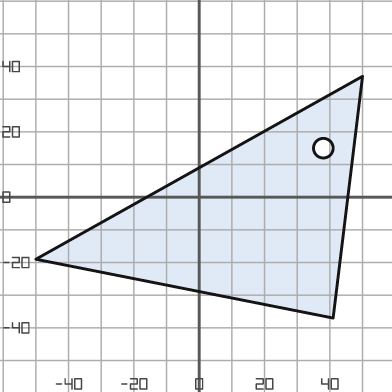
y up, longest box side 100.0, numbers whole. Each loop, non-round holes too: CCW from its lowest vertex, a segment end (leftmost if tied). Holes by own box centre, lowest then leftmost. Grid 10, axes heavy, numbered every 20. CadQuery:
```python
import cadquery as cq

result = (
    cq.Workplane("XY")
    .moveTo(41.0, -37.0)
    .lineTo(50.0, 37.0)
    .lineTo(-50.0, -19.0)
    .close()
    .moveTo(38.0, 15.0)
    .circle(3.0)
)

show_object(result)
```